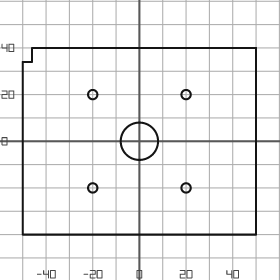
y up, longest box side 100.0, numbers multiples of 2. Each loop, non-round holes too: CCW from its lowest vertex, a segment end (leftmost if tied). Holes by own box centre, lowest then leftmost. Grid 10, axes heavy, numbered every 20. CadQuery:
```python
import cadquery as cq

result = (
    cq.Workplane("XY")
    .moveTo(-50.0, -40.0)
    .lineTo(50.0, -40.0)
    .lineTo(50.0, 40.0)
    .lineTo(-46.0, 40.0)
    .lineTo(-46.0, 34.0)
    .lineTo(-50.0, 34.0)
    .close()
    .moveTo(-20.0, -20.0)
    .circle(2.0)
    .moveTo(20.0, -20.0)
    .circle(2.0)
    .moveTo(0.0, 0.0)
    .circle(8.0)
    .moveTo(-20.0, 20.0)
    .circle(2.0)
    .moveTo(20.0, 20.0)
    .circle(2.0)
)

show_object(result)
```